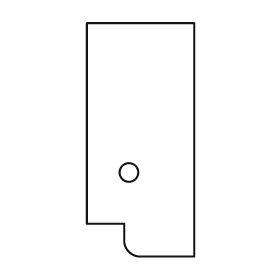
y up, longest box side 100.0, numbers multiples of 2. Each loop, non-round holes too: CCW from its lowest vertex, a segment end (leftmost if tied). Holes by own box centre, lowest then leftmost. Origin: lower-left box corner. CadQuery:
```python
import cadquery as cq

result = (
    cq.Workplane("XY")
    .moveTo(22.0, 0.0)
    .lineTo(46.0, 0.0)
    .lineTo(46.0, 100.0)
    .lineTo(0.0, 100.0)
    .lineTo(0.0, 14.0)
    .lineTo(16.0, 14.0)
    .lineTo(16.0, 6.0)
    .threePointArc((18.0, 2.0), (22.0, 0.0))
    .close()
    .moveTo(18.0, 36.0)
    .circle(4.0)
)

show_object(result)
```